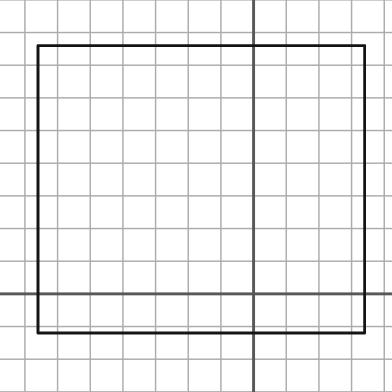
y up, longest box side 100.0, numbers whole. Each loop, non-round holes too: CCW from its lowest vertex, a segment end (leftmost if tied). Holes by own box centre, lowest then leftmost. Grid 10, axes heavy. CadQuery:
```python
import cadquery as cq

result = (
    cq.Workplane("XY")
    .moveTo(-66.0, -12.0)
    .lineTo(34.0, -12.0)
    .lineTo(34.0, 76.0)
    .lineTo(-66.0, 76.0)
    .close()
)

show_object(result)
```